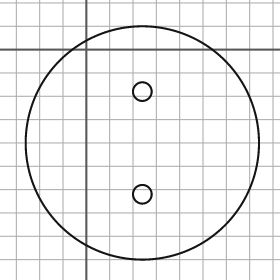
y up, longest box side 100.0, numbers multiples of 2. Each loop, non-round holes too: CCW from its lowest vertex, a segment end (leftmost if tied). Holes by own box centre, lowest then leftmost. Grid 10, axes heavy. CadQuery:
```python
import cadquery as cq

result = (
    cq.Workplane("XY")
    .moveTo(24.0, -40.0)
    .circle(50.0)
    .moveTo(24.0, -62.0)
    .circle(4.0)
    .moveTo(24.0, -18.0)
    .circle(4.0)
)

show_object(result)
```